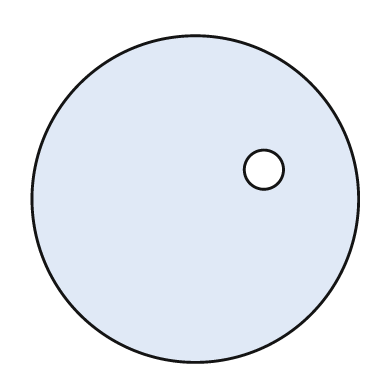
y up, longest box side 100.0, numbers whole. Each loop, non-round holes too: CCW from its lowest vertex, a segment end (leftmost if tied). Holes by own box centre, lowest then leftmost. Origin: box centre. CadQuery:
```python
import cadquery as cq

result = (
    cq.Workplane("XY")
    .moveTo(0.0, 0.0)
    .circle(50.0)
    .moveTo(21.0, 9.0)
    .circle(6.0)
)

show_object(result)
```